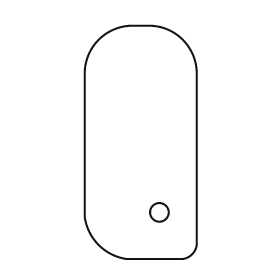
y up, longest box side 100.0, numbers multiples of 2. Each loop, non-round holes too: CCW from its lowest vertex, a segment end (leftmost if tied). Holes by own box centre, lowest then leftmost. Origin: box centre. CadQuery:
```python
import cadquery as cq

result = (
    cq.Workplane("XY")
    .moveTo(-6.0, -50.0)
    .lineTo(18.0, -50.0)
    .threePointArc((22.0, -48.0), (24.0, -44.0))
    .lineTo(24.0, 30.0)
    .threePointArc((18.0, 44.0), (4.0, 50.0))
    .lineTo(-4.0, 50.0)
    .threePointArc((-18.0, 44.0), (-24.0, 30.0))
    .lineTo(-24.0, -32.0)
    .threePointArc((-18.0, -44.0), (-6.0, -50.0))
    .close()
    .moveTo(8.0, -30.0)
    .circle(4.0)
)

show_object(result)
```